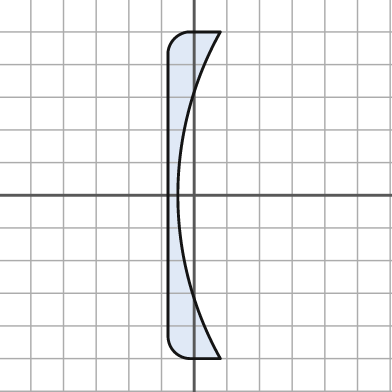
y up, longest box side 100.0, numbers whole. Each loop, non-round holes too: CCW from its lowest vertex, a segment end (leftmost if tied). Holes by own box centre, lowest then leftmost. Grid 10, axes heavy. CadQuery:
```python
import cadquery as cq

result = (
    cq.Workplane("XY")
    .moveTo(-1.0, -50.0)
    .lineTo(8.0, -50.0)
    .threePointArc((-5.0, 0.0), (8.0, 50.0))
    .lineTo(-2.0, 50.0)
    .threePointArc((-6.0, 48.0), (-8.0, 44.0))
    .lineTo(-8.0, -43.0)
    .threePointArc((-6.0, -48.0), (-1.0, -50.0))
    .close()
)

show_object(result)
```